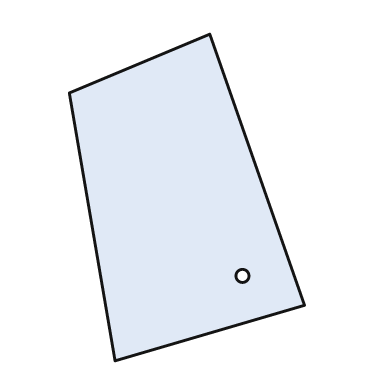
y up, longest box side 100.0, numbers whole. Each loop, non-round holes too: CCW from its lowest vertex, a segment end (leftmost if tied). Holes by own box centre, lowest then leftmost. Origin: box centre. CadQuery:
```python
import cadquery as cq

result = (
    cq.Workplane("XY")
    .moveTo(-22.0, -50.0)
    .lineTo(36.0, -33.0)
    .lineTo(7.0, 50.0)
    .lineTo(-36.0, 32.0)
    .close()
    .moveTo(17.0, -24.0)
    .circle(2.0)
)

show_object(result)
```